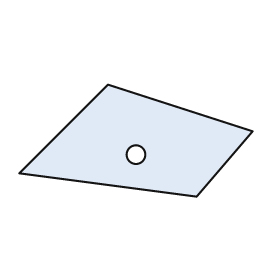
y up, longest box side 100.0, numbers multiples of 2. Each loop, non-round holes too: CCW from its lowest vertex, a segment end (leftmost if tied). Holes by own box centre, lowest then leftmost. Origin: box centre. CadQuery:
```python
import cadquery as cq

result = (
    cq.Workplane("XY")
    .moveTo(26.0, -24.0)
    .lineTo(50.0, 4.0)
    .lineTo(-12.0, 24.0)
    .lineTo(-50.0, -14.0)
    .close()
    .moveTo(0.0, -6.0)
    .circle(4.0)
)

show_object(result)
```